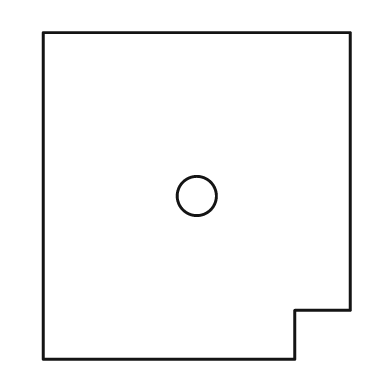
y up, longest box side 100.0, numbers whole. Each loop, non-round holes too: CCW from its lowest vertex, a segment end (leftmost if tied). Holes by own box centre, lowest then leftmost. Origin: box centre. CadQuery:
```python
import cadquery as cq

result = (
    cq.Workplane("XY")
    .moveTo(-47.0, -50.0)
    .lineTo(30.0, -50.0)
    .lineTo(30.0, -35.0)
    .lineTo(47.0, -35.0)
    .lineTo(47.0, 50.0)
    .lineTo(-47.0, 50.0)
    .close()
    .moveTo(0.0, 0.0)
    .circle(6.0)
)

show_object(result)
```